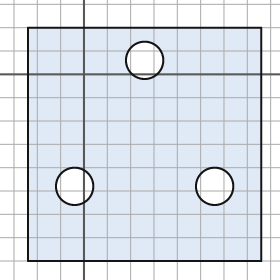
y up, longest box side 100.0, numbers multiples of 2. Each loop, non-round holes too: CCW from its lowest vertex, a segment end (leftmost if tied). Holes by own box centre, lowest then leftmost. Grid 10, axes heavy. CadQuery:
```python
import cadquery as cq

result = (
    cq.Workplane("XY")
    .moveTo(-24.0, -80.0)
    .lineTo(76.0, -80.0)
    .lineTo(76.0, 20.0)
    .lineTo(-24.0, 20.0)
    .close()
    .moveTo(-4.0, -48.0)
    .circle(8.0)
    .moveTo(56.0, -48.0)
    .circle(8.0)
    .moveTo(26.0, 6.0)
    .circle(8.0)
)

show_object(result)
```